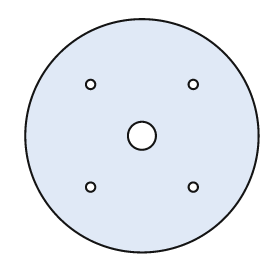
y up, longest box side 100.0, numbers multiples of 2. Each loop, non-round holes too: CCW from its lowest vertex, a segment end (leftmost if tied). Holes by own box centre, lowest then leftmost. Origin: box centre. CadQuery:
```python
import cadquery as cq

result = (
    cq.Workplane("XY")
    .moveTo(0.0, 0.0)
    .circle(50.0)
    .moveTo(-22.0, -22.0)
    .circle(2.0)
    .moveTo(22.0, -22.0)
    .circle(2.0)
    .moveTo(0.0, 0.0)
    .circle(6.0)
    .moveTo(-22.0, 22.0)
    .circle(2.0)
    .moveTo(22.0, 22.0)
    .circle(2.0)
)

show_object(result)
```